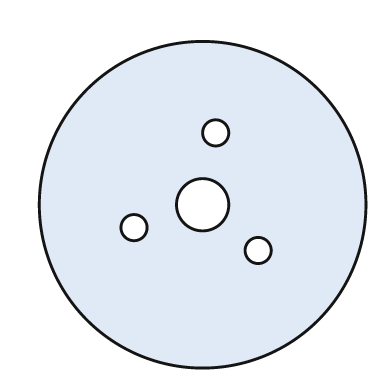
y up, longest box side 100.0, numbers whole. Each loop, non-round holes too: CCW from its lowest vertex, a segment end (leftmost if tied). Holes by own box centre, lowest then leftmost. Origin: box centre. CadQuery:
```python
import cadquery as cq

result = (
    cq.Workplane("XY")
    .moveTo(0.0, 0.0)
    .circle(50.0)
    .moveTo(17.0, -14.0)
    .circle(4.0)
    .moveTo(-21.0, -7.0)
    .circle(4.0)
    .moveTo(0.0, 0.0)
    .circle(8.0)
    .moveTo(4.0, 22.0)
    .circle(4.0)
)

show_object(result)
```